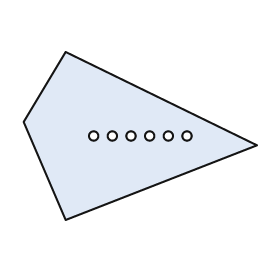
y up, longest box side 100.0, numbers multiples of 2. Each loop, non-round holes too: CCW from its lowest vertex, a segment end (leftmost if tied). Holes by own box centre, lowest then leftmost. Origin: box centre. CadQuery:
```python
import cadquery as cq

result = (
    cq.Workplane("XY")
    .moveTo(-32.0, -36.0)
    .lineTo(50.0, -4.0)
    .lineTo(-32.0, 36.0)
    .lineTo(-50.0, 6.0)
    .close()
    .moveTo(-20.0, 0.0)
    .circle(2.0)
    .moveTo(-12.0, 0.0)
    .circle(2.0)
    .moveTo(-4.0, 0.0)
    .circle(2.0)
    .moveTo(4.0, 0.0)
    .circle(2.0)
    .moveTo(12.0, 0.0)
    .circle(2.0)
    .moveTo(20.0, 0.0)
    .circle(2.0)
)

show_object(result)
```